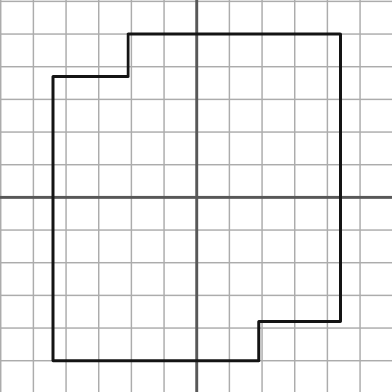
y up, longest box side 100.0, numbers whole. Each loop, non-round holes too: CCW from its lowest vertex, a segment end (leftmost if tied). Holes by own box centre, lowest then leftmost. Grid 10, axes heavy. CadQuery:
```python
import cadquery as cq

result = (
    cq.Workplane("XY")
    .moveTo(-44.0, -50.0)
    .lineTo(19.0, -50.0)
    .lineTo(19.0, -38.0)
    .lineTo(44.0, -38.0)
    .lineTo(44.0, 50.0)
    .lineTo(-21.0, 50.0)
    .lineTo(-21.0, 37.0)
    .lineTo(-44.0, 37.0)
    .close()
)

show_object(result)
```